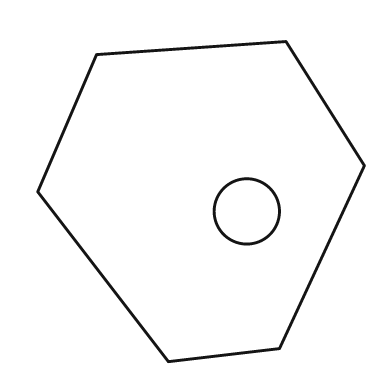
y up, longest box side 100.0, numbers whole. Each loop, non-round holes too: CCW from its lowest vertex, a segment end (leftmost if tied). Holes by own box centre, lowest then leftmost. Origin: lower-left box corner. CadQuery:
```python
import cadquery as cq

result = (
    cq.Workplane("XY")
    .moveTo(40.0, 0.0)
    .lineTo(74.0, 4.0)
    .lineTo(100.0, 60.0)
    .lineTo(76.0, 98.0)
    .lineTo(18.0, 94.0)
    .lineTo(0.0, 52.0)
    .close()
    .moveTo(64.0, 46.0)
    .circle(10.0)
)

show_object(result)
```